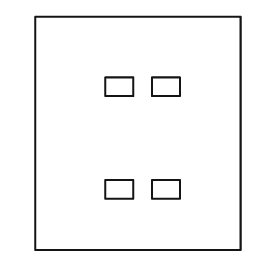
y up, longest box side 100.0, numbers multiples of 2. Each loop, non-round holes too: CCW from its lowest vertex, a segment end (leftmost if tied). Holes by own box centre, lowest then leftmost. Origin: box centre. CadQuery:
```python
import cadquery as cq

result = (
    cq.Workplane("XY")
    .moveTo(-44.0, -50.0)
    .lineTo(44.0, -50.0)
    .lineTo(44.0, 50.0)
    .lineTo(-44.0, 50.0)
    .close()
    .moveTo(-14.0, -28.0)
    .lineTo(-2.0, -28.0)
    .lineTo(-2.0, -20.0)
    .lineTo(-14.0, -20.0)
    .close()
    .moveTo(6.0, -28.0)
    .lineTo(18.0, -28.0)
    .lineTo(18.0, -20.0)
    .lineTo(6.0, -20.0)
    .close()
    .moveTo(-14.0, 16.0)
    .lineTo(-2.0, 16.0)
    .lineTo(-2.0, 24.0)
    .lineTo(-14.0, 24.0)
    .close()
    .moveTo(6.0, 16.0)
    .lineTo(18.0, 16.0)
    .lineTo(18.0, 24.0)
    .lineTo(6.0, 24.0)
    .close()
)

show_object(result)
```